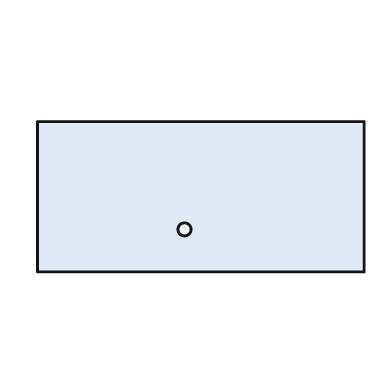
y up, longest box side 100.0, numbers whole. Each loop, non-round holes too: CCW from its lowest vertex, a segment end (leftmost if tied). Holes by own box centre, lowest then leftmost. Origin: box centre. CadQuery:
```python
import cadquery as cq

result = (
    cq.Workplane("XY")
    .moveTo(-50.0, -23.0)
    .lineTo(50.0, -23.0)
    .lineTo(50.0, 23.0)
    .lineTo(-50.0, 23.0)
    .close()
    .moveTo(-5.0, -10.0)
    .circle(2.0)
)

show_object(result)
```